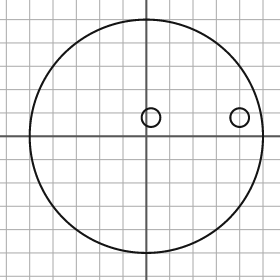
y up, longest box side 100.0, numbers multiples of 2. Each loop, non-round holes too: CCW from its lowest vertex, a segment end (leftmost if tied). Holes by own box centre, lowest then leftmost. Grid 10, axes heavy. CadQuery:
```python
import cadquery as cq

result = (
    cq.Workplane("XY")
    .moveTo(0.0, 0.0)
    .circle(50.0)
    .moveTo(2.0, 8.0)
    .circle(4.0)
    .moveTo(40.0, 8.0)
    .circle(4.0)
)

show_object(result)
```